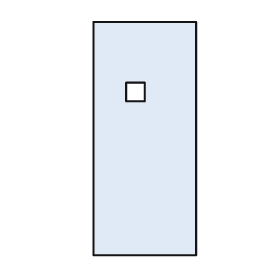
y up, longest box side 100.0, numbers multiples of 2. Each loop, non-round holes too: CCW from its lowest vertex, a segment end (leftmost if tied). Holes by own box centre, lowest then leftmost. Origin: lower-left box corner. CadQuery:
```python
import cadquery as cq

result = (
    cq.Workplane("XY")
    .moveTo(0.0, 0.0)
    .lineTo(44.0, 0.0)
    .lineTo(44.0, 100.0)
    .lineTo(0.0, 100.0)
    .close()
    .moveTo(14.0, 66.0)
    .lineTo(22.0, 66.0)
    .lineTo(22.0, 74.0)
    .lineTo(14.0, 74.0)
    .close()
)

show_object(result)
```